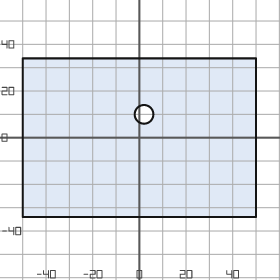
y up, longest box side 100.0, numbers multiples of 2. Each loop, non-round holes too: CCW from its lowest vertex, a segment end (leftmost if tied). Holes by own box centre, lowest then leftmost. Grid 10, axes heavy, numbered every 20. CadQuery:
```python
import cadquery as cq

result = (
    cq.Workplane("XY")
    .moveTo(-50.0, -34.0)
    .lineTo(50.0, -34.0)
    .lineTo(50.0, 34.0)
    .lineTo(-50.0, 34.0)
    .close()
    .moveTo(2.0, 10.0)
    .circle(4.0)
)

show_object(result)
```